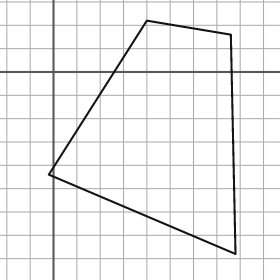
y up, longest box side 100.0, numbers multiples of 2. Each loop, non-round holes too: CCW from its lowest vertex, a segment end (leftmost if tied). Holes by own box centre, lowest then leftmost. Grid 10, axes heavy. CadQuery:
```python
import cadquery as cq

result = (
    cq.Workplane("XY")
    .moveTo(78.0, -78.0)
    .lineTo(76.0, 16.0)
    .lineTo(40.0, 22.0)
    .lineTo(-2.0, -44.0)
    .close()
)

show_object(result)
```